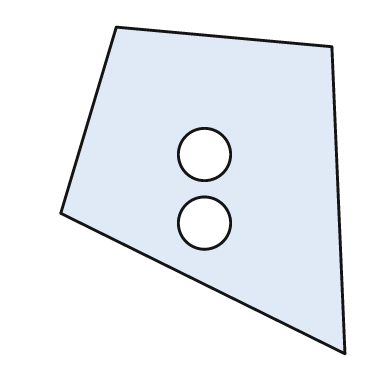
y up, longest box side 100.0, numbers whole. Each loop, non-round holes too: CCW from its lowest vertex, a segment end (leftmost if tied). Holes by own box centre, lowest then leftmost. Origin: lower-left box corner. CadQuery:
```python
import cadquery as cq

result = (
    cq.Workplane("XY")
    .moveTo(87.0, 0.0)
    .lineTo(83.0, 94.0)
    .lineTo(17.0, 100.0)
    .lineTo(0.0, 43.0)
    .close()
    .moveTo(44.0, 40.0)
    .circle(8.0)
    .moveTo(44.0, 61.0)
    .circle(8.0)
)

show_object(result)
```